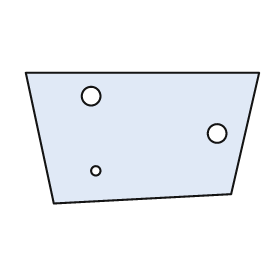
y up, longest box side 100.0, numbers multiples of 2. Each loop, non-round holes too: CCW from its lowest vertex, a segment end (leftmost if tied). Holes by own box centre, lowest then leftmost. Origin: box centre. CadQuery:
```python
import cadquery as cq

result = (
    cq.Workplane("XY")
    .moveTo(-38.0, -28.0)
    .lineTo(38.0, -24.0)
    .lineTo(50.0, 28.0)
    .lineTo(-50.0, 28.0)
    .close()
    .moveTo(-20.0, -14.0)
    .circle(2.0)
    .moveTo(32.0, 2.0)
    .circle(4.0)
    .moveTo(-22.0, 18.0)
    .circle(4.0)
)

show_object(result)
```